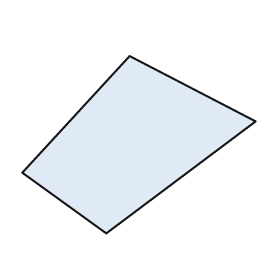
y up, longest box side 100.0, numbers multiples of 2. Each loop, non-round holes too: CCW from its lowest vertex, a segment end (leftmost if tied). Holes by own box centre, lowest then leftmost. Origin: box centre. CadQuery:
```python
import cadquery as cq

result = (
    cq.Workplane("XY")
    .moveTo(-14.0, -38.0)
    .lineTo(50.0, 10.0)
    .lineTo(-4.0, 38.0)
    .lineTo(-50.0, -12.0)
    .close()
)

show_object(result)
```